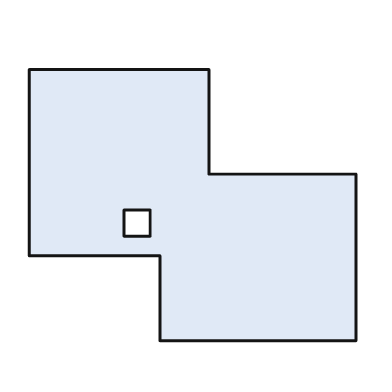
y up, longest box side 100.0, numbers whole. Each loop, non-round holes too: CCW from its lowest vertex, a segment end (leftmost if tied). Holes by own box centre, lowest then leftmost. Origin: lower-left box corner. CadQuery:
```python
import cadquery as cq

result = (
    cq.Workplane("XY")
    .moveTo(40.0, 0.0)
    .lineTo(100.0, 0.0)
    .lineTo(100.0, 51.0)
    .lineTo(55.0, 51.0)
    .lineTo(55.0, 83.0)
    .lineTo(0.0, 83.0)
    .lineTo(0.0, 26.0)
    .lineTo(40.0, 26.0)
    .close()
    .moveTo(29.0, 32.0)
    .lineTo(37.0, 32.0)
    .lineTo(37.0, 40.0)
    .lineTo(29.0, 40.0)
    .close()
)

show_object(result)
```